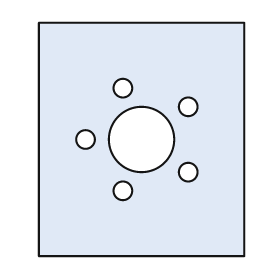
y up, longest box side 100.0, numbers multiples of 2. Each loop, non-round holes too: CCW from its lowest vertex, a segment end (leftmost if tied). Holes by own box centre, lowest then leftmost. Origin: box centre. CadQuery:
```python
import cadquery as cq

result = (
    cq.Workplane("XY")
    .moveTo(-44.0, -50.0)
    .lineTo(44.0, -50.0)
    .lineTo(44.0, 50.0)
    .lineTo(-44.0, 50.0)
    .close()
    .moveTo(-8.0, -22.0)
    .circle(4.0)
    .moveTo(20.0, -14.0)
    .circle(4.0)
    .moveTo(-24.0, 0.0)
    .circle(4.0)
    .moveTo(0.0, 0.0)
    .circle(14.0)
    .moveTo(20.0, 14.0)
    .circle(4.0)
    .moveTo(-8.0, 22.0)
    .circle(4.0)
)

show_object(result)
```